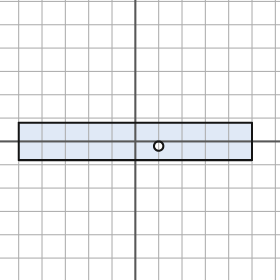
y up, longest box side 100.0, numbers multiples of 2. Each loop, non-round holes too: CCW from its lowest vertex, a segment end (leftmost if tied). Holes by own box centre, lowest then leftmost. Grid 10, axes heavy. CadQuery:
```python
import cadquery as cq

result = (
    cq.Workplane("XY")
    .moveTo(-50.0, -8.0)
    .lineTo(50.0, -8.0)
    .lineTo(50.0, 8.0)
    .lineTo(-50.0, 8.0)
    .close()
    .moveTo(10.0, -2.0)
    .circle(2.0)
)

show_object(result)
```